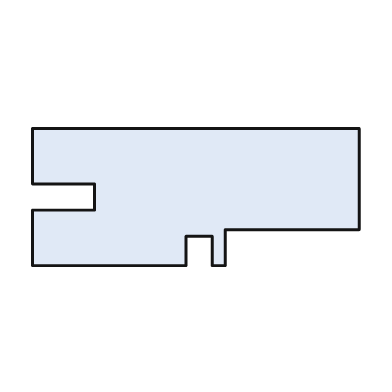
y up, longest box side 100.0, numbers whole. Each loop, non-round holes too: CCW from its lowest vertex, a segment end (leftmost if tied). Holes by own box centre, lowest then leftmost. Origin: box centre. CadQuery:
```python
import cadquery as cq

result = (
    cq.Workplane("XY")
    .moveTo(-50.0, -21.0)
    .lineTo(-3.0, -21.0)
    .lineTo(-3.0, -12.0)
    .lineTo(5.0, -12.0)
    .lineTo(5.0, -21.0)
    .lineTo(9.0, -21.0)
    .lineTo(9.0, -10.0)
    .lineTo(50.0, -10.0)
    .lineTo(50.0, 21.0)
    .lineTo(-50.0, 21.0)
    .lineTo(-50.0, 4.0)
    .lineTo(-31.0, 4.0)
    .lineTo(-31.0, -4.0)
    .lineTo(-50.0, -4.0)
    .close()
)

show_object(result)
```